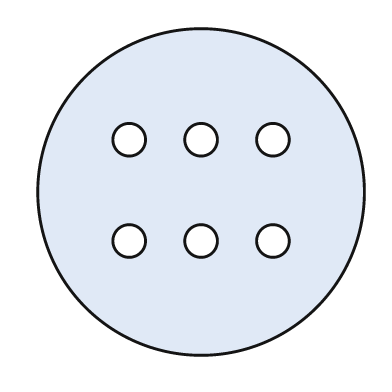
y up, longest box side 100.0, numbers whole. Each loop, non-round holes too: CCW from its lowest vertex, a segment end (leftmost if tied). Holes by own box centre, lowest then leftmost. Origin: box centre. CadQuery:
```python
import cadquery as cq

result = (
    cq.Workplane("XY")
    .moveTo(0.0, 0.0)
    .circle(50.0)
    .moveTo(-22.0, -15.0)
    .circle(5.0)
    .moveTo(0.0, -15.0)
    .circle(5.0)
    .moveTo(22.0, -15.0)
    .circle(5.0)
    .moveTo(-22.0, 16.0)
    .circle(5.0)
    .moveTo(0.0, 16.0)
    .circle(5.0)
    .moveTo(22.0, 16.0)
    .circle(5.0)
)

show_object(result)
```